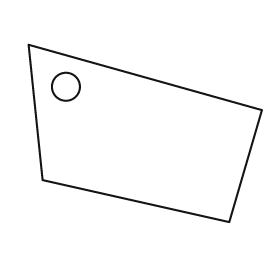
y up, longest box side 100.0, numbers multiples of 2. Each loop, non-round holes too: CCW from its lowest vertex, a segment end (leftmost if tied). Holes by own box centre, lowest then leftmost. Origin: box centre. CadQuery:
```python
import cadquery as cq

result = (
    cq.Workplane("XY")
    .moveTo(36.0, -38.0)
    .lineTo(50.0, 10.0)
    .lineTo(-50.0, 38.0)
    .lineTo(-44.0, -20.0)
    .close()
    .moveTo(-34.0, 20.0)
    .circle(6.0)
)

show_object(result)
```